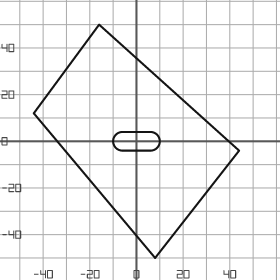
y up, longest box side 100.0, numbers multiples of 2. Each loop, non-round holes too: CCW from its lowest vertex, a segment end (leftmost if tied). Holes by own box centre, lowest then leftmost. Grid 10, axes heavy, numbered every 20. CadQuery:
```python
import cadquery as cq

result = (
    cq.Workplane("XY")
    .moveTo(8.0, -50.0)
    .lineTo(44.0, -4.0)
    .lineTo(-16.0, 50.0)
    .lineTo(-44.0, 12.0)
    .close()
    .moveTo(-6.0, -4.0)
    .lineTo(6.0, -4.0)
    .threePointArc((10.0, 0.0), (6.0, 4.0))
    .lineTo(-6.0, 4.0)
    .threePointArc((-10.0, 0.0), (-6.0, -4.0))
    .close()
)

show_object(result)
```